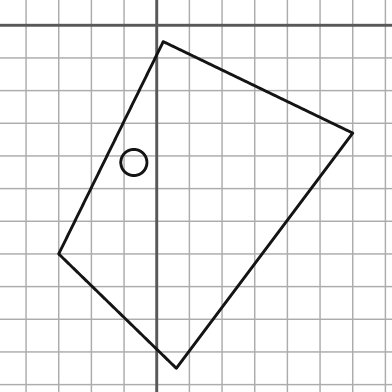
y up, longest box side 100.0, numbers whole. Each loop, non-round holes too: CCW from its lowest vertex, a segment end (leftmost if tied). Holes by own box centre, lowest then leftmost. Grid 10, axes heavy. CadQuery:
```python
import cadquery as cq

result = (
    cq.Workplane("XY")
    .moveTo(6.0, -105.0)
    .lineTo(60.0, -33.0)
    .lineTo(2.0, -5.0)
    .lineTo(-30.0, -70.0)
    .close()
    .moveTo(-7.0, -42.0)
    .circle(4.0)
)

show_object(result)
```